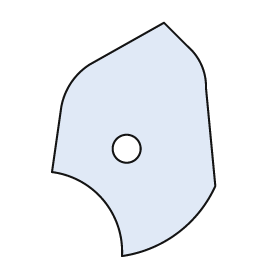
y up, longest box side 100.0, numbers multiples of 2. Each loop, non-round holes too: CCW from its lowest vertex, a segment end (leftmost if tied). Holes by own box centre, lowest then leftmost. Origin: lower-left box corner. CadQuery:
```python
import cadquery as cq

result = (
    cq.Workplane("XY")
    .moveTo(30.0, 0.0)
    .threePointArc((54.0, 10.0), (70.0, 30.0))
    .lineTo(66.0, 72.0)
    .threePointArc((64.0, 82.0), (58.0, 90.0))
    .lineTo(48.0, 100.0)
    .lineTo(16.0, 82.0)
    .threePointArc((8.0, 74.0), (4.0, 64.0))
    .lineTo(0.0, 36.0)
    .threePointArc((22.0, 24.0), (30.0, 0.0))
    .close()
    .moveTo(32.0, 46.0)
    .circle(6.0)
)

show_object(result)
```